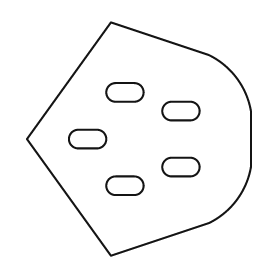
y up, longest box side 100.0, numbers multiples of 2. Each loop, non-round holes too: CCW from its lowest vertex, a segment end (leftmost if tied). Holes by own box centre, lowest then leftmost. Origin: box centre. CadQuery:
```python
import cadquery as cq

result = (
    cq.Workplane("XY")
    .moveTo(-12.0, -50.0)
    .lineTo(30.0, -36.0)
    .threePointArc((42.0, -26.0), (48.0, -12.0))
    .lineTo(48.0, 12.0)
    .threePointArc((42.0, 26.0), (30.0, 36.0))
    .lineTo(-12.0, 50.0)
    .lineTo(-48.0, 0.0)
    .close()
    .moveTo(-10.0, -24.0)
    .lineTo(-2.0, -24.0)
    .threePointArc((2.0, -20.0), (-2.0, -16.0))
    .lineTo(-10.0, -16.0)
    .threePointArc((-14.0, -20.0), (-10.0, -24.0))
    .close()
    .moveTo(14.0, -16.0)
    .lineTo(22.0, -16.0)
    .threePointArc((26.0, -12.0), (22.0, -8.0))
    .lineTo(14.0, -8.0)
    .threePointArc((10.0, -12.0), (14.0, -16.0))
    .close()
    .moveTo(-26.0, -4.0)
    .lineTo(-18.0, -4.0)
    .threePointArc((-14.0, 0.0), (-18.0, 4.0))
    .lineTo(-26.0, 4.0)
    .threePointArc((-30.0, 0.0), (-26.0, -4.0))
    .close()
    .moveTo(14.0, 8.0)
    .lineTo(22.0, 8.0)
    .threePointArc((26.0, 12.0), (22.0, 16.0))
    .lineTo(14.0, 16.0)
    .threePointArc((10.0, 12.0), (14.0, 8.0))
    .close()
    .moveTo(-10.0, 16.0)
    .lineTo(-2.0, 16.0)
    .threePointArc((2.0, 20.0), (-2.0, 24.0))
    .lineTo(-10.0, 24.0)
    .threePointArc((-14.0, 20.0), (-10.0, 16.0))
    .close()
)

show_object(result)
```